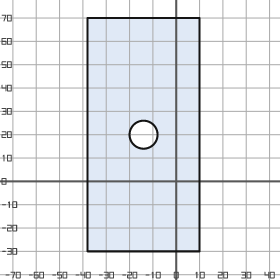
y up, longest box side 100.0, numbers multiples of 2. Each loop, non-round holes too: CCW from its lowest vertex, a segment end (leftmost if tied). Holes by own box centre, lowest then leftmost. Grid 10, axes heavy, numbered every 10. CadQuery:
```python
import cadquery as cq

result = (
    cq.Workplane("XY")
    .moveTo(-38.0, -30.0)
    .lineTo(10.0, -30.0)
    .lineTo(10.0, 70.0)
    .lineTo(-38.0, 70.0)
    .close()
    .moveTo(-14.0, 20.0)
    .circle(6.0)
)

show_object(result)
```